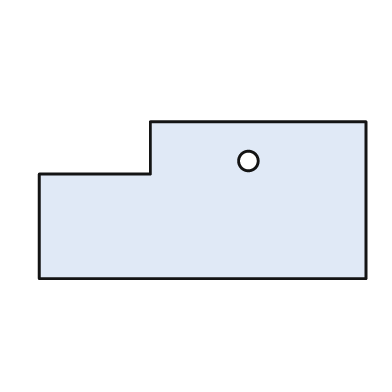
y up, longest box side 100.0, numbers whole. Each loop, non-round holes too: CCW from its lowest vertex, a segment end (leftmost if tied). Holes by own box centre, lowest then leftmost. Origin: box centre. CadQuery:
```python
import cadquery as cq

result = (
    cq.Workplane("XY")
    .moveTo(-50.0, -24.0)
    .lineTo(50.0, -24.0)
    .lineTo(50.0, 24.0)
    .lineTo(-16.0, 24.0)
    .lineTo(-16.0, 8.0)
    .lineTo(-50.0, 8.0)
    .close()
    .moveTo(14.0, 12.0)
    .circle(3.0)
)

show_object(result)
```